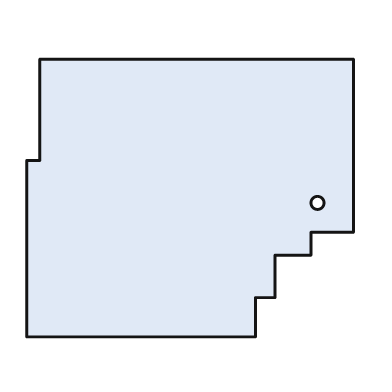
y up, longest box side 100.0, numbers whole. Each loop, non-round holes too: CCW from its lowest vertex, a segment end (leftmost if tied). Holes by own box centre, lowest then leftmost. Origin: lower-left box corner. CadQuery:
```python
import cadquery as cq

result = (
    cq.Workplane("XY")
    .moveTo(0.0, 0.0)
    .lineTo(70.0, 0.0)
    .lineTo(70.0, 12.0)
    .lineTo(76.0, 12.0)
    .lineTo(76.0, 25.0)
    .lineTo(87.0, 25.0)
    .lineTo(87.0, 32.0)
    .lineTo(100.0, 32.0)
    .lineTo(100.0, 85.0)
    .lineTo(4.0, 85.0)
    .lineTo(4.0, 54.0)
    .lineTo(0.0, 54.0)
    .close()
    .moveTo(89.0, 41.0)
    .circle(2.0)
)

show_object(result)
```